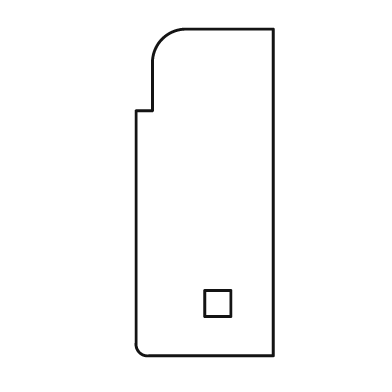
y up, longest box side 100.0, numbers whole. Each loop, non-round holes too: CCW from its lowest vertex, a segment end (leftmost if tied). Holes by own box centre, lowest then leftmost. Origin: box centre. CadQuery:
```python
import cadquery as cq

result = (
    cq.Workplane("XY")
    .moveTo(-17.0, -50.0)
    .lineTo(21.0, -50.0)
    .lineTo(21.0, 50.0)
    .lineTo(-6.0, 50.0)
    .threePointArc((-13.0, 47.0), (-16.0, 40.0))
    .lineTo(-16.0, 25.0)
    .lineTo(-21.0, 25.0)
    .lineTo(-21.0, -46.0)
    .threePointArc((-20.0, -49.0), (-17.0, -50.0))
    .close()
    .moveTo(0.0, -38.0)
    .lineTo(8.0, -38.0)
    .lineTo(8.0, -30.0)
    .lineTo(0.0, -30.0)
    .close()
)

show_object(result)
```